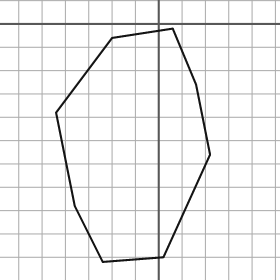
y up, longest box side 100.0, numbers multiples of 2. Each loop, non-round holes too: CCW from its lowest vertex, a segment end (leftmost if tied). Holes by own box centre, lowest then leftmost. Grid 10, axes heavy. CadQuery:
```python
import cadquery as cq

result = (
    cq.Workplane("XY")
    .moveTo(-24.0, -102.0)
    .lineTo(2.0, -100.0)
    .lineTo(22.0, -56.0)
    .lineTo(16.0, -26.0)
    .lineTo(6.0, -2.0)
    .lineTo(-20.0, -6.0)
    .lineTo(-44.0, -38.0)
    .lineTo(-36.0, -78.0)
    .close()
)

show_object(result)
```